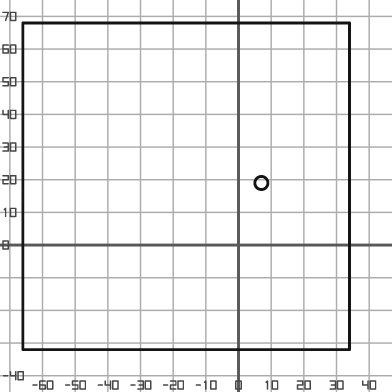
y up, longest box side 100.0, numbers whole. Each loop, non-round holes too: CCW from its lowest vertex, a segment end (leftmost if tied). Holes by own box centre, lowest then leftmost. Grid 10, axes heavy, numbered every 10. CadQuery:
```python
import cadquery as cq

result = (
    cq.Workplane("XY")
    .moveTo(-66.0, -32.0)
    .lineTo(34.0, -32.0)
    .lineTo(34.0, 68.0)
    .lineTo(-66.0, 68.0)
    .close()
    .moveTo(7.0, 19.0)
    .circle(2.0)
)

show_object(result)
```